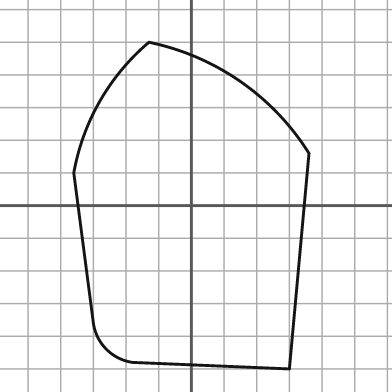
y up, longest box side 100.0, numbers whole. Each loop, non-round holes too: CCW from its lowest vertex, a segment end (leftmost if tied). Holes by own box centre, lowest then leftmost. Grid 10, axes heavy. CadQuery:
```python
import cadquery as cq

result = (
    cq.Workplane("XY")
    .moveTo(30.0, -50.0)
    .lineTo(36.0, 16.0)
    .threePointArc((15.0, 38.0), (-13.0, 50.0))
    .threePointArc((-28.0, 32.0), (-36.0, 10.0))
    .lineTo(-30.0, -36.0)
    .threePointArc((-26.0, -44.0), (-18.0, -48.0))
    .close()
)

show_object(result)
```